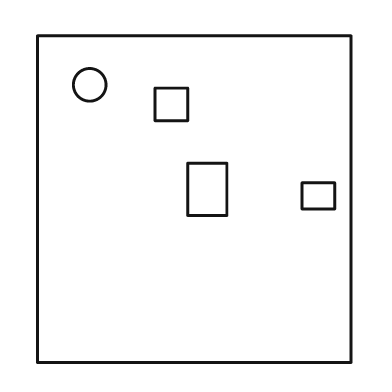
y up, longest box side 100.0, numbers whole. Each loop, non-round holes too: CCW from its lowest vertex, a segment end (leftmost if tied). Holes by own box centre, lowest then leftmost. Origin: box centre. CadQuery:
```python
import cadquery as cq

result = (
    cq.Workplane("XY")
    .moveTo(-48.0, -50.0)
    .lineTo(48.0, -50.0)
    .lineTo(48.0, 50.0)
    .lineTo(-48.0, 50.0)
    .close()
    .moveTo(33.0, -3.0)
    .lineTo(43.0, -3.0)
    .lineTo(43.0, 5.0)
    .lineTo(33.0, 5.0)
    .close()
    .moveTo(-2.0, -5.0)
    .lineTo(10.0, -5.0)
    .lineTo(10.0, 11.0)
    .lineTo(-2.0, 11.0)
    .close()
    .moveTo(-12.0, 24.0)
    .lineTo(-2.0, 24.0)
    .lineTo(-2.0, 34.0)
    .lineTo(-12.0, 34.0)
    .close()
    .moveTo(-32.0, 35.0)
    .circle(5.0)
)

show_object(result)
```